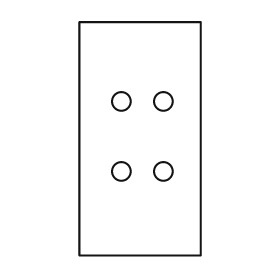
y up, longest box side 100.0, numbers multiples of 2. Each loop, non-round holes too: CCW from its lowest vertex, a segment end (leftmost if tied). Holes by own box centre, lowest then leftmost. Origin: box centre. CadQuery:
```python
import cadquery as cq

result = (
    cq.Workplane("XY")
    .moveTo(-26.0, -50.0)
    .lineTo(26.0, -50.0)
    .lineTo(26.0, 50.0)
    .lineTo(-26.0, 50.0)
    .close()
    .moveTo(-8.0, -14.0)
    .circle(4.0)
    .moveTo(10.0, -14.0)
    .circle(4.0)
    .moveTo(-8.0, 16.0)
    .circle(4.0)
    .moveTo(10.0, 16.0)
    .circle(4.0)
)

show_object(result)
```